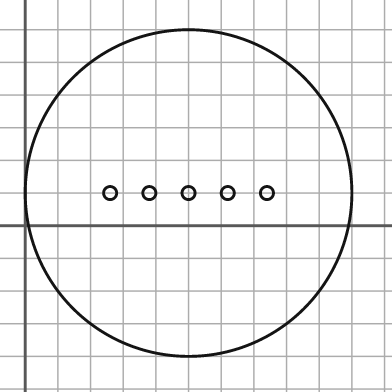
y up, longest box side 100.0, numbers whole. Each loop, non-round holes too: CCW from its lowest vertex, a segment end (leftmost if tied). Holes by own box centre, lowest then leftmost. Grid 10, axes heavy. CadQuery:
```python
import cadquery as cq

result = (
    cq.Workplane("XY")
    .moveTo(50.0, 10.0)
    .circle(50.0)
    .moveTo(26.0, 10.0)
    .circle(2.0)
    .moveTo(38.0, 10.0)
    .circle(2.0)
    .moveTo(50.0, 10.0)
    .circle(2.0)
    .moveTo(62.0, 10.0)
    .circle(2.0)
    .moveTo(74.0, 10.0)
    .circle(2.0)
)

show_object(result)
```